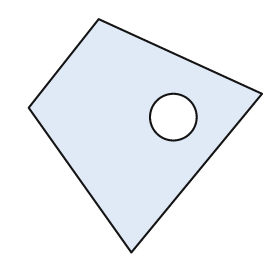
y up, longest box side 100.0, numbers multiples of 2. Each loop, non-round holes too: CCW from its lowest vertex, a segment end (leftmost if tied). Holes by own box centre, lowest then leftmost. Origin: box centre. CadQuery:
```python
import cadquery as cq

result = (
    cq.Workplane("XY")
    .moveTo(-6.0, -50.0)
    .lineTo(50.0, 18.0)
    .lineTo(-20.0, 50.0)
    .lineTo(-50.0, 12.0)
    .close()
    .moveTo(12.0, 8.0)
    .circle(10.0)
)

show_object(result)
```